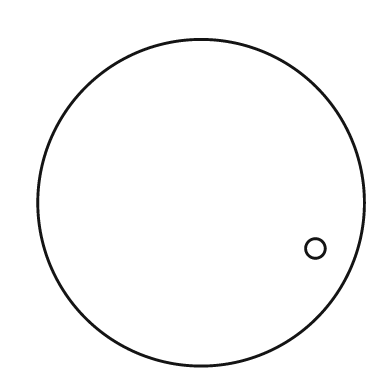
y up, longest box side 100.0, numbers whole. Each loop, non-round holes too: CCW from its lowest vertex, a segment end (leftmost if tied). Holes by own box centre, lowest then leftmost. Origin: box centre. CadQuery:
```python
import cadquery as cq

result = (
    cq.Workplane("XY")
    .moveTo(0.0, 0.0)
    .circle(50.0)
    .moveTo(35.0, -14.0)
    .circle(3.0)
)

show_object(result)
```